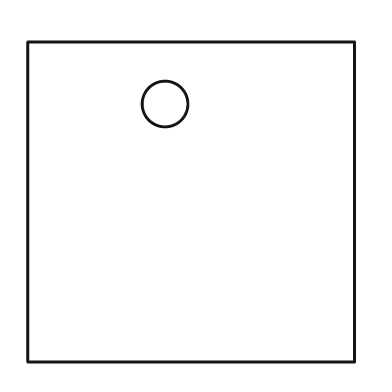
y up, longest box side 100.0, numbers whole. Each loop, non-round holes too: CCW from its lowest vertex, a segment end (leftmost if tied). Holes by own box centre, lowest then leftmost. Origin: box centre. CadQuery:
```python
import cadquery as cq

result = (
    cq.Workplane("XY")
    .moveTo(-50.0, -49.0)
    .lineTo(50.0, -49.0)
    .lineTo(50.0, 49.0)
    .lineTo(-50.0, 49.0)
    .close()
    .moveTo(-8.0, 30.0)
    .circle(7.0)
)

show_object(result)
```